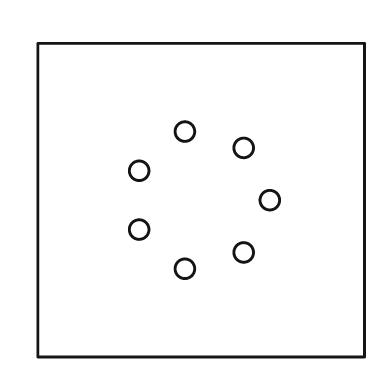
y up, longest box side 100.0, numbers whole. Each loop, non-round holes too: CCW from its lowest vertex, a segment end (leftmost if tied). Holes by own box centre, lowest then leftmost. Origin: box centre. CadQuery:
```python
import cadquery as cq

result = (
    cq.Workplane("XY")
    .moveTo(-50.0, -48.0)
    .lineTo(50.0, -48.0)
    .lineTo(50.0, 48.0)
    .lineTo(-50.0, 48.0)
    .close()
    .moveTo(-5.0, -21.0)
    .circle(3.0)
    .moveTo(13.0, -16.0)
    .circle(3.0)
    .moveTo(-19.0, -9.0)
    .circle(3.0)
    .moveTo(21.0, 0.0)
    .circle(3.0)
    .moveTo(-19.0, 9.0)
    .circle(3.0)
    .moveTo(13.0, 16.0)
    .circle(3.0)
    .moveTo(-5.0, 21.0)
    .circle(3.0)
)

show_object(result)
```